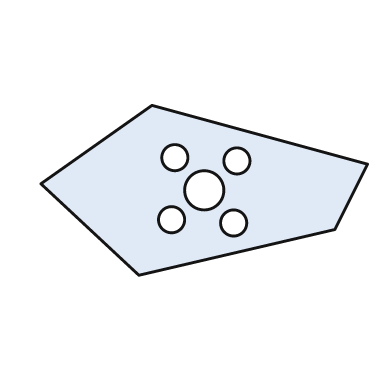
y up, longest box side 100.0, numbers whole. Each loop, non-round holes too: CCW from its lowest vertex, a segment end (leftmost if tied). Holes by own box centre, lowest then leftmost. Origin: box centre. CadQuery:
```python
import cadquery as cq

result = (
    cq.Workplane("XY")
    .moveTo(-20.0, -26.0)
    .lineTo(40.0, -12.0)
    .lineTo(50.0, 8.0)
    .lineTo(-16.0, 26.0)
    .lineTo(-50.0, 2.0)
    .close()
    .moveTo(9.0, -10.0)
    .circle(4.0)
    .moveTo(-10.0, -9.0)
    .circle(4.0)
    .moveTo(0.0, 0.0)
    .circle(6.0)
    .moveTo(10.0, 9.0)
    .circle(4.0)
    .moveTo(-9.0, 10.0)
    .circle(4.0)
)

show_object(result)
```